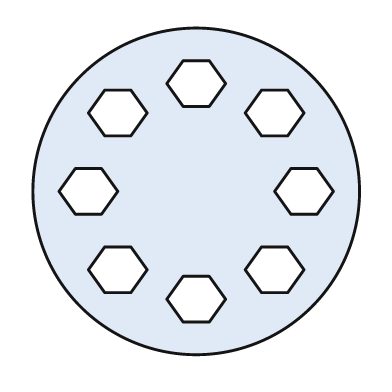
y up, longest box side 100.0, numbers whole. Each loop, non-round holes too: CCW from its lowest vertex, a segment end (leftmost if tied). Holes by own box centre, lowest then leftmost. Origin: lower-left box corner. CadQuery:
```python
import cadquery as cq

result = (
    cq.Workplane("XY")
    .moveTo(50.0, 50.0)
    .circle(50.0)
    .moveTo(46.0, 10.0)
    .lineTo(54.0, 10.0)
    .lineTo(59.0, 17.0)
    .lineTo(54.0, 24.0)
    .lineTo(46.0, 24.0)
    .lineTo(41.0, 17.0)
    .close()
    .moveTo(22.0, 19.0)
    .lineTo(30.0, 19.0)
    .lineTo(35.0, 26.0)
    .lineTo(30.0, 33.0)
    .lineTo(22.0, 33.0)
    .lineTo(17.0, 26.0)
    .close()
    .moveTo(70.0, 19.0)
    .lineTo(78.0, 19.0)
    .lineTo(83.0, 26.0)
    .lineTo(78.0, 33.0)
    .lineTo(70.0, 33.0)
    .lineTo(65.0, 26.0)
    .close()
    .moveTo(13.0, 43.0)
    .lineTo(21.0, 43.0)
    .lineTo(26.0, 50.0)
    .lineTo(21.0, 57.0)
    .lineTo(13.0, 57.0)
    .lineTo(8.0, 50.0)
    .close()
    .moveTo(79.0, 43.0)
    .lineTo(87.0, 43.0)
    .lineTo(92.0, 50.0)
    .lineTo(87.0, 57.0)
    .lineTo(79.0, 57.0)
    .lineTo(74.0, 50.0)
    .close()
    .moveTo(22.0, 67.0)
    .lineTo(30.0, 67.0)
    .lineTo(35.0, 74.0)
    .lineTo(30.0, 81.0)
    .lineTo(22.0, 81.0)
    .lineTo(17.0, 74.0)
    .close()
    .moveTo(70.0, 67.0)
    .lineTo(78.0, 67.0)
    .lineTo(83.0, 74.0)
    .lineTo(78.0, 81.0)
    .lineTo(70.0, 81.0)
    .lineTo(65.0, 74.0)
    .close()
    .moveTo(46.0, 76.0)
    .lineTo(54.0, 76.0)
    .lineTo(59.0, 83.0)
    .lineTo(54.0, 90.0)
    .lineTo(46.0, 90.0)
    .lineTo(41.0, 83.0)
    .close()
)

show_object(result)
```